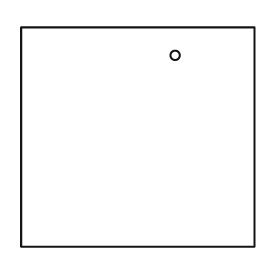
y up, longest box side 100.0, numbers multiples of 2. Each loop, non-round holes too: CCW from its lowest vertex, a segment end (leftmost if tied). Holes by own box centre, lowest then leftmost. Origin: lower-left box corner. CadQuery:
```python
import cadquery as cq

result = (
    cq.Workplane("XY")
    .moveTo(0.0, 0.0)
    .lineTo(100.0, 0.0)
    .lineTo(100.0, 94.0)
    .lineTo(0.0, 94.0)
    .close()
    .moveTo(66.0, 82.0)
    .circle(2.0)
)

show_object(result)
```